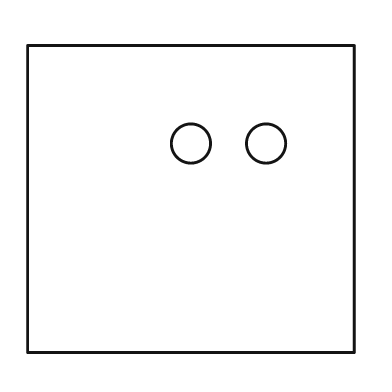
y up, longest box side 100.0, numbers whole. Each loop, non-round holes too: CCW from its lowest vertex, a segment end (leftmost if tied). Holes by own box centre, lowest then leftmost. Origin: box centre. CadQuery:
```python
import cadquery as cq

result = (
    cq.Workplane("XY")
    .moveTo(-50.0, -47.0)
    .lineTo(50.0, -47.0)
    .lineTo(50.0, 47.0)
    .lineTo(-50.0, 47.0)
    .close()
    .moveTo(0.0, 17.0)
    .circle(6.0)
    .moveTo(23.0, 17.0)
    .circle(6.0)
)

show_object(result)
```